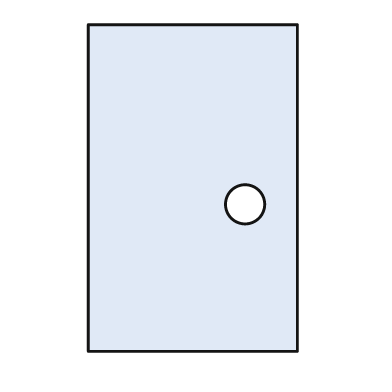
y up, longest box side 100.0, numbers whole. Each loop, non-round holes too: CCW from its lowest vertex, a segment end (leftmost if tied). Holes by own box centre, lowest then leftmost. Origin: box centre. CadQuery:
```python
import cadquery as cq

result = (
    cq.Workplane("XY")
    .moveTo(-32.0, -50.0)
    .lineTo(32.0, -50.0)
    .lineTo(32.0, 50.0)
    .lineTo(-32.0, 50.0)
    .close()
    .moveTo(16.0, -5.0)
    .circle(6.0)
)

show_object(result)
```